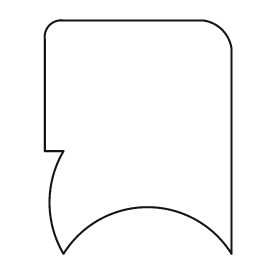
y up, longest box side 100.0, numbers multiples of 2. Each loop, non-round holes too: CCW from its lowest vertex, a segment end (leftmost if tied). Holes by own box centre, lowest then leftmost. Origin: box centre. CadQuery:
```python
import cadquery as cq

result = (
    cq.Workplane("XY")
    .moveTo(-32.0, -50.0)
    .threePointArc((4.0, -30.0), (40.0, -50.0))
    .lineTo(40.0, 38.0)
    .threePointArc((36.0, 46.0), (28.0, 50.0))
    .lineTo(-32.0, 50.0)
    .threePointArc((-38.0, 48.0), (-40.0, 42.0))
    .lineTo(-40.0, -6.0)
    .lineTo(-32.0, -6.0)
    .threePointArc((-38.0, -28.0), (-32.0, -50.0))
    .close()
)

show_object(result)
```